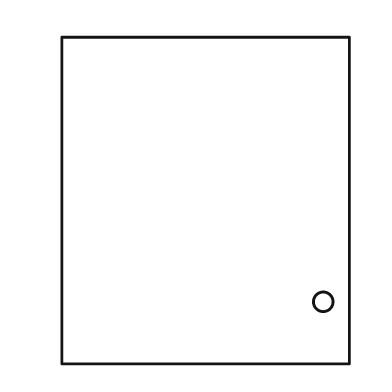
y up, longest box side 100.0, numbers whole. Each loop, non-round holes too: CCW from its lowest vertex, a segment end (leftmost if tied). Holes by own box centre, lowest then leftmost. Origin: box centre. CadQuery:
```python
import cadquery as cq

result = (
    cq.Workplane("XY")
    .moveTo(-44.0, -50.0)
    .lineTo(44.0, -50.0)
    .lineTo(44.0, 50.0)
    .lineTo(-44.0, 50.0)
    .close()
    .moveTo(36.0, -31.0)
    .circle(3.0)
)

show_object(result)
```